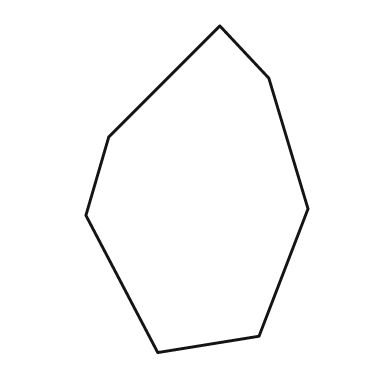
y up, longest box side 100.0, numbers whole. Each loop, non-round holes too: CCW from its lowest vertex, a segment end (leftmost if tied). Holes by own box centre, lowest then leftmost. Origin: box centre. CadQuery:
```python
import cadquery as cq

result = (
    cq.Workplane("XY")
    .moveTo(-12.0, -50.0)
    .lineTo(19.0, -45.0)
    .lineTo(34.0, -6.0)
    .lineTo(22.0, 34.0)
    .lineTo(7.0, 50.0)
    .lineTo(-27.0, 16.0)
    .lineTo(-34.0, -8.0)
    .close()
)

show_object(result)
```